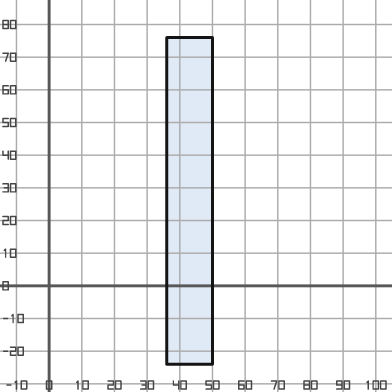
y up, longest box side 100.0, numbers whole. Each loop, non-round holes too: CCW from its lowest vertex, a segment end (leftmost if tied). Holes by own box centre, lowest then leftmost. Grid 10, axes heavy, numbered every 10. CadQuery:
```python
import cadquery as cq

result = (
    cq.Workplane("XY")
    .moveTo(36.0, -24.0)
    .lineTo(50.0, -24.0)
    .lineTo(50.0, 76.0)
    .lineTo(36.0, 76.0)
    .close()
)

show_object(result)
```